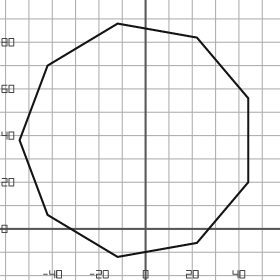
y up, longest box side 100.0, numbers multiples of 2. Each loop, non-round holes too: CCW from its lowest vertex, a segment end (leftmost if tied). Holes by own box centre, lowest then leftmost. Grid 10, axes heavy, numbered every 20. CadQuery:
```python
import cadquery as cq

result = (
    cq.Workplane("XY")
    .moveTo(-12.0, -12.0)
    .lineTo(22.0, -6.0)
    .lineTo(44.0, 20.0)
    .lineTo(44.0, 56.0)
    .lineTo(22.0, 82.0)
    .lineTo(-12.0, 88.0)
    .lineTo(-42.0, 70.0)
    .lineTo(-54.0, 38.0)
    .lineTo(-42.0, 6.0)
    .close()
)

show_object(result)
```